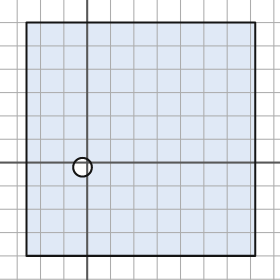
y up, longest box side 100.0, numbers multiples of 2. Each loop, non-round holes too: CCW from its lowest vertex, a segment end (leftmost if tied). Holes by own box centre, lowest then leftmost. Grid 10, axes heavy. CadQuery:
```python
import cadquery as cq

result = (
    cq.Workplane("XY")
    .moveTo(-26.0, -40.0)
    .lineTo(72.0, -40.0)
    .lineTo(72.0, 60.0)
    .lineTo(-26.0, 60.0)
    .close()
    .moveTo(-2.0, -2.0)
    .circle(4.0)
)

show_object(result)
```